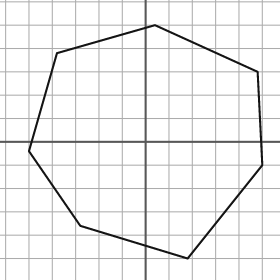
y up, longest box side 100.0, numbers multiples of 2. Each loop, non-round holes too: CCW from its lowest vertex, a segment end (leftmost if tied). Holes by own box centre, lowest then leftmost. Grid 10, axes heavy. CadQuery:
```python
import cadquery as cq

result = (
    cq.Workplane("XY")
    .moveTo(18.0, -50.0)
    .lineTo(50.0, -10.0)
    .lineTo(48.0, 30.0)
    .lineTo(4.0, 50.0)
    .lineTo(-38.0, 38.0)
    .lineTo(-50.0, -4.0)
    .lineTo(-28.0, -36.0)
    .close()
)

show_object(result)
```